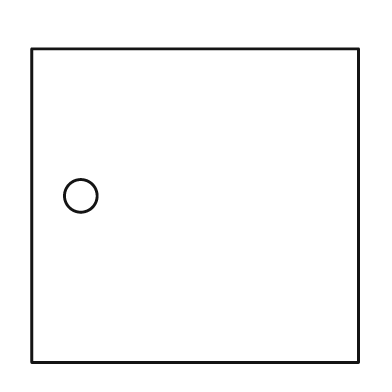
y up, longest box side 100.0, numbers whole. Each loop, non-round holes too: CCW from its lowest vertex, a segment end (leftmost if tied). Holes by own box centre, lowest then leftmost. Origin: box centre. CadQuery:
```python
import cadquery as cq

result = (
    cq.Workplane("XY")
    .moveTo(-50.0, -48.0)
    .lineTo(50.0, -48.0)
    .lineTo(50.0, 48.0)
    .lineTo(-50.0, 48.0)
    .close()
    .moveTo(-35.0, 3.0)
    .circle(5.0)
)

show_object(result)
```